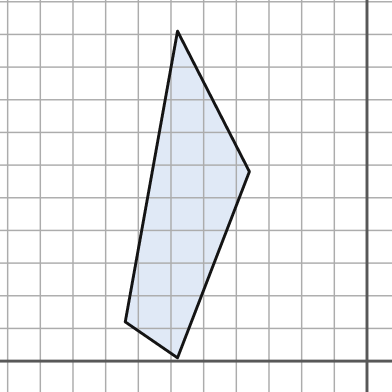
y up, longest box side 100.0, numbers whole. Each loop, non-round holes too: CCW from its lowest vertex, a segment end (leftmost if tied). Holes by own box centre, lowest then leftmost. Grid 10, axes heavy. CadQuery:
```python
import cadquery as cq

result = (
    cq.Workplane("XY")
    .moveTo(-58.0, 1.0)
    .lineTo(-36.0, 58.0)
    .lineTo(-58.0, 101.0)
    .lineTo(-74.0, 12.0)
    .close()
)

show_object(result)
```